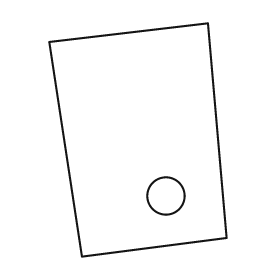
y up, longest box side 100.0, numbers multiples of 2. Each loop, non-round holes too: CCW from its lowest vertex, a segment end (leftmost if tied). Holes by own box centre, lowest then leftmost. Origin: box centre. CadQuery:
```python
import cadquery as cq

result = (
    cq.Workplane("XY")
    .moveTo(-24.0, -50.0)
    .lineTo(38.0, -42.0)
    .lineTo(30.0, 50.0)
    .lineTo(-38.0, 42.0)
    .close()
    .moveTo(12.0, -24.0)
    .circle(8.0)
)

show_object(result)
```